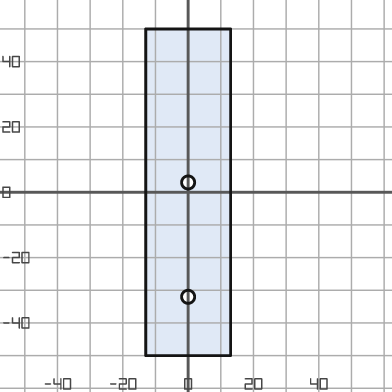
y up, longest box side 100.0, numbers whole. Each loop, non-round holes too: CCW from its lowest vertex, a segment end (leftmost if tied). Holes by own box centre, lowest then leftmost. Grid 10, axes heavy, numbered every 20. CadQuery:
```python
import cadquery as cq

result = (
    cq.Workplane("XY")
    .moveTo(-13.0, -50.0)
    .lineTo(13.0, -50.0)
    .lineTo(13.0, 50.0)
    .lineTo(-13.0, 50.0)
    .close()
    .moveTo(0.0, -32.0)
    .circle(2.0)
    .moveTo(0.0, 3.0)
    .circle(2.0)
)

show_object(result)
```